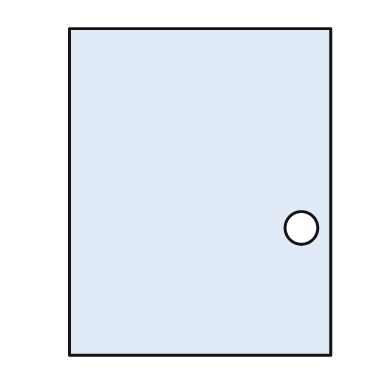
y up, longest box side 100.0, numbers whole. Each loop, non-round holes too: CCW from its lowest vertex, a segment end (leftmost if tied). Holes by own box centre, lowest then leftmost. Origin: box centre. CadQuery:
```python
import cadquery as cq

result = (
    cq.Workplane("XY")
    .moveTo(-40.0, -50.0)
    .lineTo(40.0, -50.0)
    .lineTo(40.0, 50.0)
    .lineTo(-40.0, 50.0)
    .close()
    .moveTo(31.0, -11.0)
    .circle(5.0)
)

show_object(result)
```